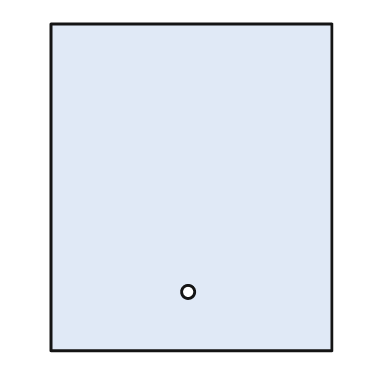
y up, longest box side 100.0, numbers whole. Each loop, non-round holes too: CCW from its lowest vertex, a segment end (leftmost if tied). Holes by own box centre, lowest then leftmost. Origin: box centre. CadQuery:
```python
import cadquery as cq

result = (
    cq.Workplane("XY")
    .moveTo(-43.0, -50.0)
    .lineTo(43.0, -50.0)
    .lineTo(43.0, 50.0)
    .lineTo(-43.0, 50.0)
    .close()
    .moveTo(-1.0, -32.0)
    .circle(2.0)
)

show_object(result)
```